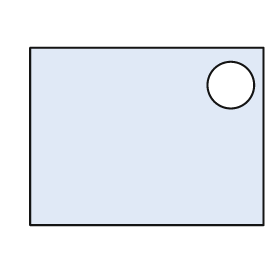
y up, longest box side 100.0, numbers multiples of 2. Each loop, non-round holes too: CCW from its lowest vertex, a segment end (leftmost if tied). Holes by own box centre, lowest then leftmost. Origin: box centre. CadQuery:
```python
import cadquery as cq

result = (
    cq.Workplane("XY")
    .moveTo(-50.0, -38.0)
    .lineTo(50.0, -38.0)
    .lineTo(50.0, 38.0)
    .lineTo(-50.0, 38.0)
    .close()
    .moveTo(36.0, 22.0)
    .circle(10.0)
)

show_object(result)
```